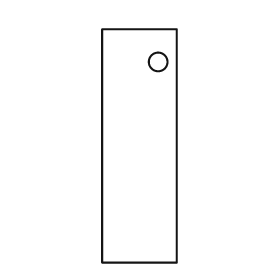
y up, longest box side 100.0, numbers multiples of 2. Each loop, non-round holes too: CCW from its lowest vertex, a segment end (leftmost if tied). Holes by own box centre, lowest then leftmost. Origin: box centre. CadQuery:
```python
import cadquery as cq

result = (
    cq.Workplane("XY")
    .moveTo(-16.0, -50.0)
    .lineTo(16.0, -50.0)
    .lineTo(16.0, 50.0)
    .lineTo(-16.0, 50.0)
    .close()
    .moveTo(8.0, 36.0)
    .circle(4.0)
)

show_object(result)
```